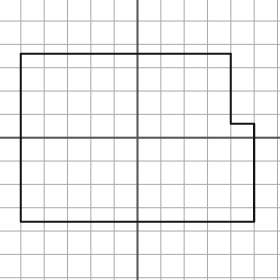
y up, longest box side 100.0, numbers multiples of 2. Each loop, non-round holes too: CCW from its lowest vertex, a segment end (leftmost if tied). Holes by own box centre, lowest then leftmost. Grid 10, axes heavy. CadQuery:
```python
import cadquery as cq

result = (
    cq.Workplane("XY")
    .moveTo(-50.0, -36.0)
    .lineTo(50.0, -36.0)
    .lineTo(50.0, 6.0)
    .lineTo(40.0, 6.0)
    .lineTo(40.0, 36.0)
    .lineTo(-50.0, 36.0)
    .close()
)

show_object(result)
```